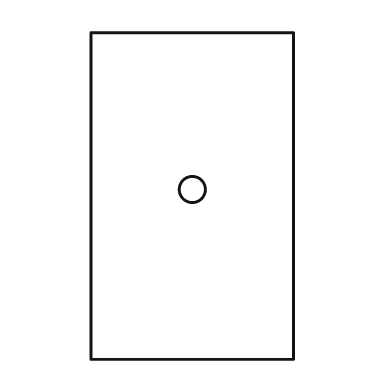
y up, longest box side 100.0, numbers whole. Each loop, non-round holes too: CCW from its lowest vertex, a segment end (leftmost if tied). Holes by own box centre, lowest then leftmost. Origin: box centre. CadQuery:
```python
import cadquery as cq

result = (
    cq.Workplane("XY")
    .moveTo(-31.0, -50.0)
    .lineTo(31.0, -50.0)
    .lineTo(31.0, 50.0)
    .lineTo(-31.0, 50.0)
    .close()
    .moveTo(0.0, 2.0)
    .circle(4.0)
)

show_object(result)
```